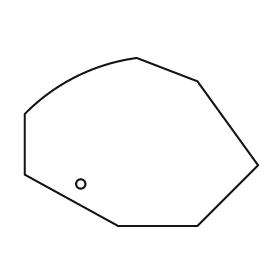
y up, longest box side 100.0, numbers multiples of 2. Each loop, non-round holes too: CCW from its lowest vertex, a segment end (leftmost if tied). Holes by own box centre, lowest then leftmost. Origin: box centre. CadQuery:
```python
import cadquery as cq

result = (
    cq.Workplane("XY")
    .moveTo(-10.0, -36.0)
    .lineTo(24.0, -36.0)
    .lineTo(50.0, -10.0)
    .lineTo(24.0, 26.0)
    .lineTo(-2.0, 36.0)
    .threePointArc((-28.0, 28.0), (-50.0, 12.0))
    .lineTo(-50.0, -14.0)
    .close()
    .moveTo(-26.0, -18.0)
    .circle(2.0)
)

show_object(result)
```